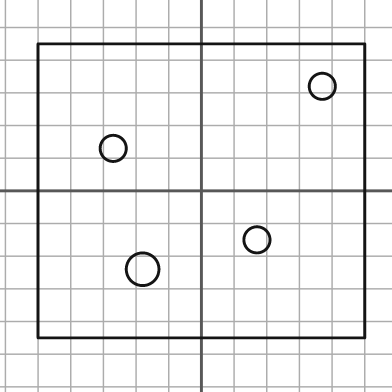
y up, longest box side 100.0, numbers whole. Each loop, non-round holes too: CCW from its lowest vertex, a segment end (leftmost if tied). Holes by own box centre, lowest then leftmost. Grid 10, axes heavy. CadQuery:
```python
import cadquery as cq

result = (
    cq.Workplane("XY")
    .moveTo(-50.0, -45.0)
    .lineTo(50.0, -45.0)
    .lineTo(50.0, 45.0)
    .lineTo(-50.0, 45.0)
    .close()
    .moveTo(-18.0, -24.0)
    .circle(5.0)
    .moveTo(17.0, -15.0)
    .circle(4.0)
    .moveTo(-27.0, 13.0)
    .circle(4.0)
    .moveTo(37.0, 32.0)
    .circle(4.0)
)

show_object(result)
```